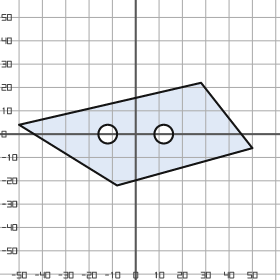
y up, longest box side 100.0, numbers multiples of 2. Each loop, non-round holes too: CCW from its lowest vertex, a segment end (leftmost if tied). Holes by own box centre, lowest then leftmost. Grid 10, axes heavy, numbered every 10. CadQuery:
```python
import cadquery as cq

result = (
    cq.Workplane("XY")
    .moveTo(-8.0, -22.0)
    .lineTo(50.0, -6.0)
    .lineTo(28.0, 22.0)
    .lineTo(-50.0, 4.0)
    .close()
    .moveTo(-12.0, 0.0)
    .circle(4.0)
    .moveTo(12.0, 0.0)
    .circle(4.0)
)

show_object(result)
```